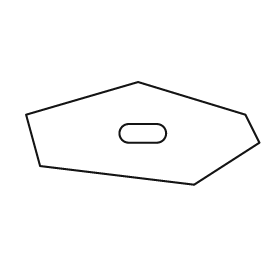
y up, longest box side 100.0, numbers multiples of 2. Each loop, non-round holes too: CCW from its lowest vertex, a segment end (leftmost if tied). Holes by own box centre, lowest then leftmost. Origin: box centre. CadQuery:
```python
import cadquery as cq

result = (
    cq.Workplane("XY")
    .moveTo(22.0, -22.0)
    .lineTo(50.0, -4.0)
    .lineTo(44.0, 8.0)
    .lineTo(-2.0, 22.0)
    .lineTo(-50.0, 8.0)
    .lineTo(-44.0, -14.0)
    .close()
    .moveTo(-6.0, -4.0)
    .lineTo(6.0, -4.0)
    .threePointArc((10.0, 0.0), (6.0, 4.0))
    .lineTo(-6.0, 4.0)
    .threePointArc((-10.0, 0.0), (-6.0, -4.0))
    .close()
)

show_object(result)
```